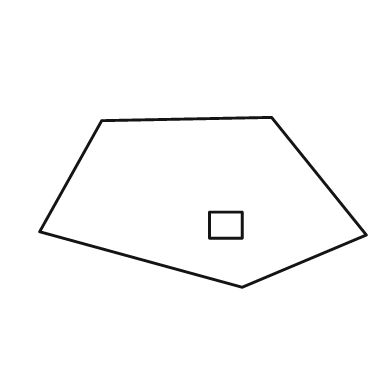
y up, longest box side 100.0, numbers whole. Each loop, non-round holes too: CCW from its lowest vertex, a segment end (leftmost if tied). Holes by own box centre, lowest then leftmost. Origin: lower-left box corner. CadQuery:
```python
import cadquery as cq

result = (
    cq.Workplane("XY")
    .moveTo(62.0, 0.0)
    .lineTo(100.0, 16.0)
    .lineTo(71.0, 52.0)
    .lineTo(19.0, 51.0)
    .lineTo(0.0, 17.0)
    .close()
    .moveTo(52.0, 15.0)
    .lineTo(62.0, 15.0)
    .lineTo(62.0, 23.0)
    .lineTo(52.0, 23.0)
    .close()
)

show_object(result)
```